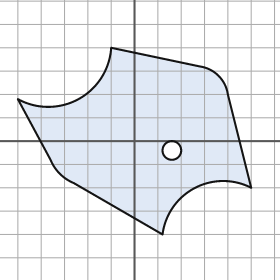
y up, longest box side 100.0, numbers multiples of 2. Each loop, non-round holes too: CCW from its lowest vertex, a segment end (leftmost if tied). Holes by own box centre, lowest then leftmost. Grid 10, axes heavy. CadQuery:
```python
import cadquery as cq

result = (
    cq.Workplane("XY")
    .moveTo(12.0, -40.0)
    .threePointArc((26.0, -20.0), (50.0, -20.0))
    .lineTo(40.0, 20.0)
    .threePointArc((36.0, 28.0), (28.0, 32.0))
    .lineTo(-10.0, 40.0)
    .threePointArc((-24.0, 18.0), (-50.0, 18.0))
    .lineTo(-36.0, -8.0)
    .threePointArc((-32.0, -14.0), (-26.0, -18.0))
    .close()
    .moveTo(16.0, -4.0)
    .circle(4.0)
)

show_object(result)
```